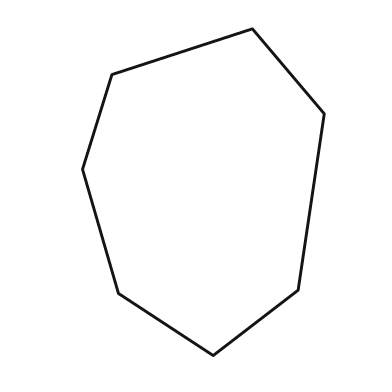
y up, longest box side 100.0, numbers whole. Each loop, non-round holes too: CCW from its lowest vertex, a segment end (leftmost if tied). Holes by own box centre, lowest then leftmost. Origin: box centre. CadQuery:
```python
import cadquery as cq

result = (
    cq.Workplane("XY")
    .moveTo(3.0, -50.0)
    .lineTo(29.0, -30.0)
    .lineTo(37.0, 24.0)
    .lineTo(15.0, 50.0)
    .lineTo(-28.0, 36.0)
    .lineTo(-37.0, 7.0)
    .lineTo(-26.0, -31.0)
    .close()
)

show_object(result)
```